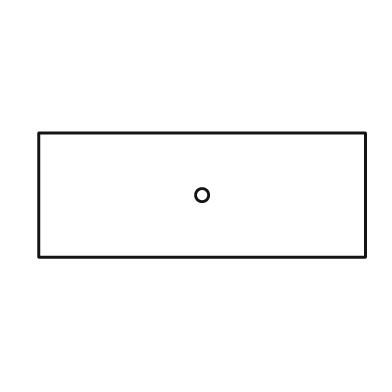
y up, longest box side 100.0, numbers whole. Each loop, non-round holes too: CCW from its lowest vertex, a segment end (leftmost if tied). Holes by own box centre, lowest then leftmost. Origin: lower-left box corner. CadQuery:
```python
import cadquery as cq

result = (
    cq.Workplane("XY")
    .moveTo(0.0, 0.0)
    .lineTo(100.0, 0.0)
    .lineTo(100.0, 38.0)
    .lineTo(0.0, 38.0)
    .close()
    .moveTo(50.0, 19.0)
    .circle(2.0)
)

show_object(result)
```